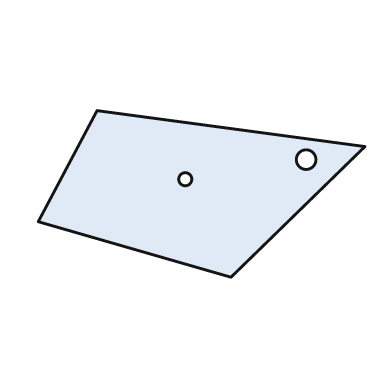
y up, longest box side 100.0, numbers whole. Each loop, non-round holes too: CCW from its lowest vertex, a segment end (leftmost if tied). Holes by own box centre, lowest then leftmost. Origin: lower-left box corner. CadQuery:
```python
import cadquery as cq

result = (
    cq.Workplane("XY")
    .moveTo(59.0, 0.0)
    .lineTo(100.0, 40.0)
    .lineTo(18.0, 51.0)
    .lineTo(0.0, 17.0)
    .close()
    .moveTo(45.0, 30.0)
    .circle(2.0)
    .moveTo(82.0, 36.0)
    .circle(3.0)
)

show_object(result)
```